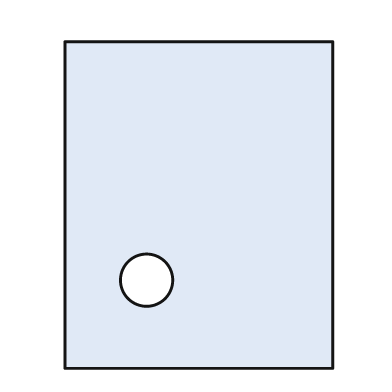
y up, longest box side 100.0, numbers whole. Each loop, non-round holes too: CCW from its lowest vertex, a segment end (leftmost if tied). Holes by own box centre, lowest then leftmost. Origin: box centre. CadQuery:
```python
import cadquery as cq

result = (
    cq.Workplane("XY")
    .moveTo(-41.0, -50.0)
    .lineTo(41.0, -50.0)
    .lineTo(41.0, 50.0)
    .lineTo(-41.0, 50.0)
    .close()
    .moveTo(-16.0, -23.0)
    .circle(8.0)
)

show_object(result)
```